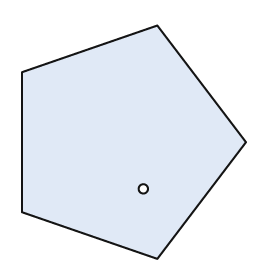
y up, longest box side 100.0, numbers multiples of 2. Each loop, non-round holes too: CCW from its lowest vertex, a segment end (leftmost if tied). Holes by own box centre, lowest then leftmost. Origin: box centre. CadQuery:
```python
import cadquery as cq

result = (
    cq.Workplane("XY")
    .moveTo(10.0, -50.0)
    .lineTo(48.0, 0.0)
    .lineTo(10.0, 50.0)
    .lineTo(-48.0, 30.0)
    .lineTo(-48.0, -30.0)
    .close()
    .moveTo(4.0, -20.0)
    .circle(2.0)
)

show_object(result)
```